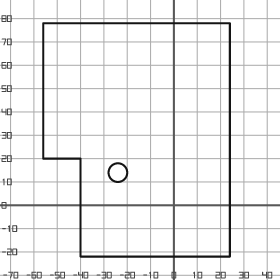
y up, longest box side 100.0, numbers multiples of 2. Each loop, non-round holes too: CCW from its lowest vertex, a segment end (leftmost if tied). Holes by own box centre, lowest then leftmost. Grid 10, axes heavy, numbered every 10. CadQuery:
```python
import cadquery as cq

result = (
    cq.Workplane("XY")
    .moveTo(-40.0, -22.0)
    .lineTo(24.0, -22.0)
    .lineTo(24.0, 78.0)
    .lineTo(-56.0, 78.0)
    .lineTo(-56.0, 20.0)
    .lineTo(-40.0, 20.0)
    .close()
    .moveTo(-24.0, 14.0)
    .circle(4.0)
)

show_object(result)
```